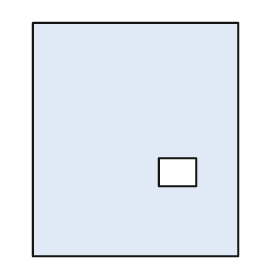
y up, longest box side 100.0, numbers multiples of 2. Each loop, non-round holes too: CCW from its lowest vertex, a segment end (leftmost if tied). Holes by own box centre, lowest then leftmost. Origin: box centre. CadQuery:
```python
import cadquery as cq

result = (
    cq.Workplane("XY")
    .moveTo(-44.0, -50.0)
    .lineTo(44.0, -50.0)
    .lineTo(44.0, 50.0)
    .lineTo(-44.0, 50.0)
    .close()
    .moveTo(10.0, -20.0)
    .lineTo(26.0, -20.0)
    .lineTo(26.0, -8.0)
    .lineTo(10.0, -8.0)
    .close()
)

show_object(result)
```